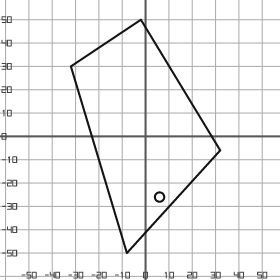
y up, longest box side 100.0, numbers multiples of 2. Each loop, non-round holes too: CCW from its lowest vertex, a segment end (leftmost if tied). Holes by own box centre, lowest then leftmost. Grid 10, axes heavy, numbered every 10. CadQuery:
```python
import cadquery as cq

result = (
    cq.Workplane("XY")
    .moveTo(-8.0, -50.0)
    .lineTo(32.0, -6.0)
    .lineTo(-2.0, 50.0)
    .lineTo(-32.0, 30.0)
    .close()
    .moveTo(6.0, -26.0)
    .circle(2.0)
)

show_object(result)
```